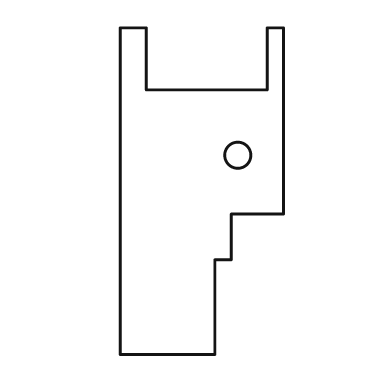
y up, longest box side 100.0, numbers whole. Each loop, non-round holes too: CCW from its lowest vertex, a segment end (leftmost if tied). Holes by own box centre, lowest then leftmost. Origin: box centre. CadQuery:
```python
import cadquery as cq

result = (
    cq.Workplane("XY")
    .moveTo(-25.0, -50.0)
    .lineTo(4.0, -50.0)
    .lineTo(4.0, -21.0)
    .lineTo(9.0, -21.0)
    .lineTo(9.0, -7.0)
    .lineTo(25.0, -7.0)
    .lineTo(25.0, 50.0)
    .lineTo(20.0, 50.0)
    .lineTo(20.0, 31.0)
    .lineTo(-17.0, 31.0)
    .lineTo(-17.0, 50.0)
    .lineTo(-25.0, 50.0)
    .close()
    .moveTo(11.0, 11.0)
    .circle(4.0)
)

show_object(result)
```